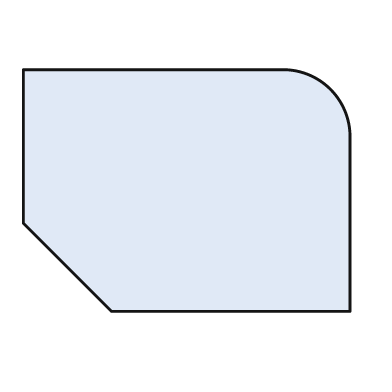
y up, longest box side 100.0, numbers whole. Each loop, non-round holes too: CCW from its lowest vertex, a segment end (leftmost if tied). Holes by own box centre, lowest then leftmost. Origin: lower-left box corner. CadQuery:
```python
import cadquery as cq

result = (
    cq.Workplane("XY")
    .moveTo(27.0, 0.0)
    .lineTo(100.0, 0.0)
    .lineTo(100.0, 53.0)
    .threePointArc((94.0, 68.0), (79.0, 74.0))
    .lineTo(0.0, 74.0)
    .lineTo(0.0, 27.0)
    .close()
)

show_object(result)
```